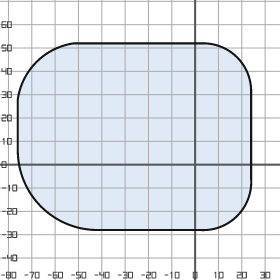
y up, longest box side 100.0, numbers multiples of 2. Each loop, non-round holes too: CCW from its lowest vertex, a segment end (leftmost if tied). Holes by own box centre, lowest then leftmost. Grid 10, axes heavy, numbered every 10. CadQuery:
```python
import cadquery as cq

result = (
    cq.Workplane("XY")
    .moveTo(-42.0, -28.0)
    .lineTo(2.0, -28.0)
    .threePointArc((18.0, -22.0), (24.0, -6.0))
    .lineTo(24.0, 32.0)
    .threePointArc((18.0, 46.0), (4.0, 52.0))
    .lineTo(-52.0, 52.0)
    .threePointArc((-68.0, 44.0), (-76.0, 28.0))
    .lineTo(-76.0, 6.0)
    .threePointArc((-66.0, -18.0), (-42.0, -28.0))
    .close()
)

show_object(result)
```